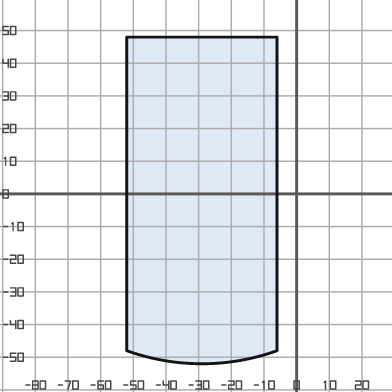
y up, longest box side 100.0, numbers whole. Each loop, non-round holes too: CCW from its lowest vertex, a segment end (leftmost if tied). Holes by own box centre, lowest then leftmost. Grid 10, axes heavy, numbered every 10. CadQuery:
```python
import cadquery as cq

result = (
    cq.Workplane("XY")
    .moveTo(-52.0, -48.0)
    .threePointArc((-29.0, -52.0), (-6.0, -48.0))
    .lineTo(-6.0, 48.0)
    .lineTo(-52.0, 48.0)
    .close()
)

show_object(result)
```